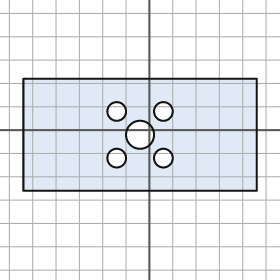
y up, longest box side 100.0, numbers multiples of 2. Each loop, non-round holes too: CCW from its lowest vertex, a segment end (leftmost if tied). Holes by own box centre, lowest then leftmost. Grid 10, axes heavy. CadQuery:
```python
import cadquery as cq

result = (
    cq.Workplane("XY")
    .moveTo(-54.0, -26.0)
    .lineTo(46.0, -26.0)
    .lineTo(46.0, 22.0)
    .lineTo(-54.0, 22.0)
    .close()
    .moveTo(-14.0, -12.0)
    .circle(4.0)
    .moveTo(6.0, -12.0)
    .circle(4.0)
    .moveTo(-4.0, -2.0)
    .circle(6.0)
    .moveTo(-14.0, 8.0)
    .circle(4.0)
    .moveTo(6.0, 8.0)
    .circle(4.0)
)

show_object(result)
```